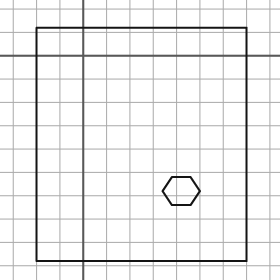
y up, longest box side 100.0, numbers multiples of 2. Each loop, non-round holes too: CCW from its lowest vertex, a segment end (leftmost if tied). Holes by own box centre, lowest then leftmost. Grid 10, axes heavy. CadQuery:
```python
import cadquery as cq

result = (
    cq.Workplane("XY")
    .moveTo(-20.0, -88.0)
    .lineTo(70.0, -88.0)
    .lineTo(70.0, 12.0)
    .lineTo(-20.0, 12.0)
    .close()
    .moveTo(38.0, -64.0)
    .lineTo(46.0, -64.0)
    .lineTo(50.0, -58.0)
    .lineTo(46.0, -52.0)
    .lineTo(38.0, -52.0)
    .lineTo(34.0, -58.0)
    .close()
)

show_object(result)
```